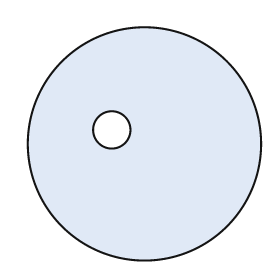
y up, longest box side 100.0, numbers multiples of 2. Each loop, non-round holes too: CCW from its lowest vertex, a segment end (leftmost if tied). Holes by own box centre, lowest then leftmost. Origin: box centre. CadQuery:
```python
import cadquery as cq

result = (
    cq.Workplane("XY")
    .moveTo(0.0, 0.0)
    .circle(50.0)
    .moveTo(-14.0, 6.0)
    .circle(8.0)
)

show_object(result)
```